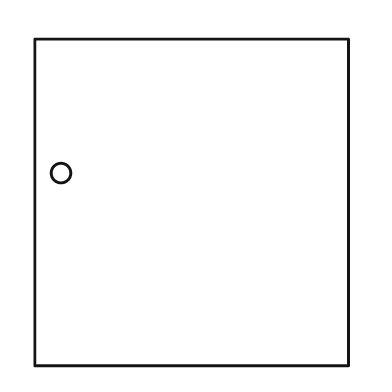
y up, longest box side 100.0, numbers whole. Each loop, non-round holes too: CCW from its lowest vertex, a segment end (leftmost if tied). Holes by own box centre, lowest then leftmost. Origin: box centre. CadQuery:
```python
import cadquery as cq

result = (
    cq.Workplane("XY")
    .moveTo(-48.0, -50.0)
    .lineTo(48.0, -50.0)
    .lineTo(48.0, 50.0)
    .lineTo(-48.0, 50.0)
    .close()
    .moveTo(-40.0, 9.0)
    .circle(3.0)
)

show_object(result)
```